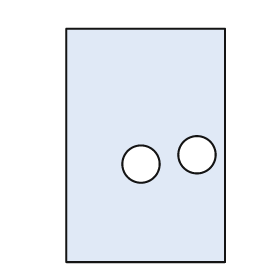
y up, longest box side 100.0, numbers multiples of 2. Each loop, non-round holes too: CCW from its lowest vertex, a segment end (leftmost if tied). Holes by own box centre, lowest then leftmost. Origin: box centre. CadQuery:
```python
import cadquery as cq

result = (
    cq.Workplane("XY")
    .moveTo(-34.0, -50.0)
    .lineTo(34.0, -50.0)
    .lineTo(34.0, 50.0)
    .lineTo(-34.0, 50.0)
    .close()
    .moveTo(-2.0, -8.0)
    .circle(8.0)
    .moveTo(22.0, -4.0)
    .circle(8.0)
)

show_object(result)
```